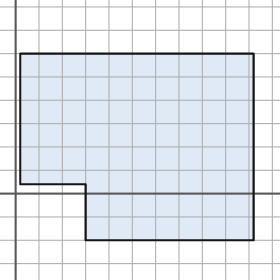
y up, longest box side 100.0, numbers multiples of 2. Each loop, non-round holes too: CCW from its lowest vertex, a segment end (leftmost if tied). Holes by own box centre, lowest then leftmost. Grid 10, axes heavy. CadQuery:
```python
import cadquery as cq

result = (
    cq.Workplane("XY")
    .moveTo(30.0, -20.0)
    .lineTo(102.0, -20.0)
    .lineTo(102.0, 60.0)
    .lineTo(2.0, 60.0)
    .lineTo(2.0, 4.0)
    .lineTo(30.0, 4.0)
    .close()
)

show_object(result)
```